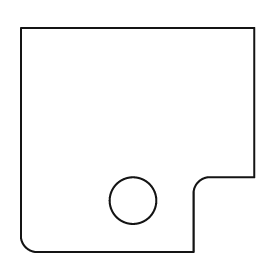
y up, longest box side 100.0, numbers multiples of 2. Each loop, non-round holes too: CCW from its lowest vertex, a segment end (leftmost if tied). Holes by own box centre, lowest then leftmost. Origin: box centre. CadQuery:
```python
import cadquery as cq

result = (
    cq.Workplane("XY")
    .moveTo(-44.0, -48.0)
    .lineTo(24.0, -48.0)
    .lineTo(24.0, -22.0)
    .threePointArc((26.0, -18.0), (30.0, -16.0))
    .lineTo(50.0, -16.0)
    .lineTo(50.0, 48.0)
    .lineTo(-50.0, 48.0)
    .lineTo(-50.0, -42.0)
    .threePointArc((-48.0, -46.0), (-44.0, -48.0))
    .close()
    .moveTo(-2.0, -26.0)
    .circle(10.0)
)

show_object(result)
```